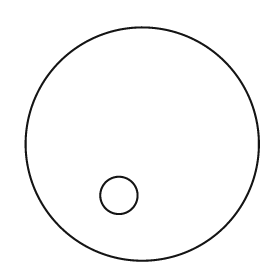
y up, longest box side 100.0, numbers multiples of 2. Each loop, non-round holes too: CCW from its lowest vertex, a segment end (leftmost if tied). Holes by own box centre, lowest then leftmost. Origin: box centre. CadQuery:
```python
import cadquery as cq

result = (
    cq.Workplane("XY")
    .moveTo(0.0, 0.0)
    .circle(50.0)
    .moveTo(-10.0, -22.0)
    .circle(8.0)
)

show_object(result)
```